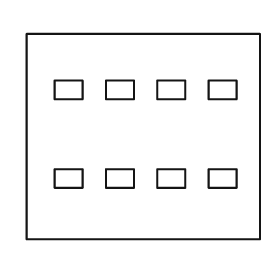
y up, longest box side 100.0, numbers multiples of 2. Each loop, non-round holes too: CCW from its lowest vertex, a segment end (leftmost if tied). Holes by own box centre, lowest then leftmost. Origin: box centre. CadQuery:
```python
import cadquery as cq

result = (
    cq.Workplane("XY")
    .moveTo(-50.0, -44.0)
    .lineTo(50.0, -44.0)
    .lineTo(50.0, 44.0)
    .lineTo(-50.0, 44.0)
    .close()
    .moveTo(-38.0, -22.0)
    .lineTo(-26.0, -22.0)
    .lineTo(-26.0, -14.0)
    .lineTo(-38.0, -14.0)
    .close()
    .moveTo(-16.0, -22.0)
    .lineTo(-4.0, -22.0)
    .lineTo(-4.0, -14.0)
    .lineTo(-16.0, -14.0)
    .close()
    .moveTo(6.0, -22.0)
    .lineTo(18.0, -22.0)
    .lineTo(18.0, -14.0)
    .lineTo(6.0, -14.0)
    .close()
    .moveTo(28.0, -22.0)
    .lineTo(40.0, -22.0)
    .lineTo(40.0, -14.0)
    .lineTo(28.0, -14.0)
    .close()
    .moveTo(-38.0, 16.0)
    .lineTo(-26.0, 16.0)
    .lineTo(-26.0, 24.0)
    .lineTo(-38.0, 24.0)
    .close()
    .moveTo(-16.0, 16.0)
    .lineTo(-4.0, 16.0)
    .lineTo(-4.0, 24.0)
    .lineTo(-16.0, 24.0)
    .close()
    .moveTo(6.0, 16.0)
    .lineTo(18.0, 16.0)
    .lineTo(18.0, 24.0)
    .lineTo(6.0, 24.0)
    .close()
    .moveTo(28.0, 16.0)
    .lineTo(40.0, 16.0)
    .lineTo(40.0, 24.0)
    .lineTo(28.0, 24.0)
    .close()
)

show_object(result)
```